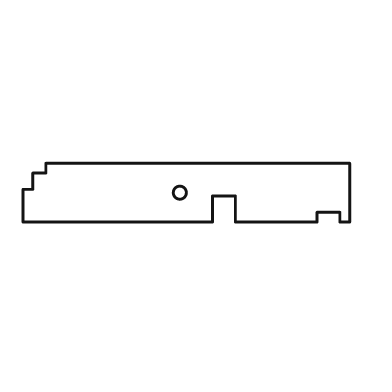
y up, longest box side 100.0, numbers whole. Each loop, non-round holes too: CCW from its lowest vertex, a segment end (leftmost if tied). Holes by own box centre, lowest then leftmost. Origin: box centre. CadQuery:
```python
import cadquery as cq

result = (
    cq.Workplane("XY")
    .moveTo(-50.0, -9.0)
    .lineTo(8.0, -9.0)
    .lineTo(8.0, -1.0)
    .lineTo(15.0, -1.0)
    .lineTo(15.0, -9.0)
    .lineTo(40.0, -9.0)
    .lineTo(40.0, -6.0)
    .lineTo(47.0, -6.0)
    .lineTo(47.0, -9.0)
    .lineTo(50.0, -9.0)
    .lineTo(50.0, 9.0)
    .lineTo(-43.0, 9.0)
    .lineTo(-43.0, 6.0)
    .lineTo(-47.0, 6.0)
    .lineTo(-47.0, 1.0)
    .lineTo(-50.0, 1.0)
    .close()
    .moveTo(-2.0, 0.0)
    .circle(2.0)
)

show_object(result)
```